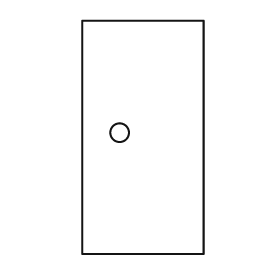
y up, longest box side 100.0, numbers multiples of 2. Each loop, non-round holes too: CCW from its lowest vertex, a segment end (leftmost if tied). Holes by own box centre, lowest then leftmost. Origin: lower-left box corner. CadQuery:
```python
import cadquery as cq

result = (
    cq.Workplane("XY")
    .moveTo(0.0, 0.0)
    .lineTo(52.0, 0.0)
    .lineTo(52.0, 100.0)
    .lineTo(0.0, 100.0)
    .close()
    .moveTo(16.0, 52.0)
    .circle(4.0)
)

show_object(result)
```